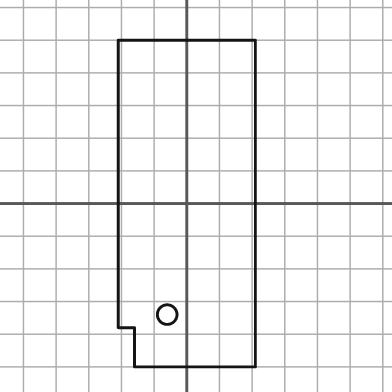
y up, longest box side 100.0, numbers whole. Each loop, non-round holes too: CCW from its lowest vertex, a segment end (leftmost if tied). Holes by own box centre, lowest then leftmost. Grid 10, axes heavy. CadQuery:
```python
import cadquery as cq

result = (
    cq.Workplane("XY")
    .moveTo(-16.0, -50.0)
    .lineTo(21.0, -50.0)
    .lineTo(21.0, 50.0)
    .lineTo(-21.0, 50.0)
    .lineTo(-21.0, -38.0)
    .lineTo(-16.0, -38.0)
    .close()
    .moveTo(-6.0, -34.0)
    .circle(3.0)
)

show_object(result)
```